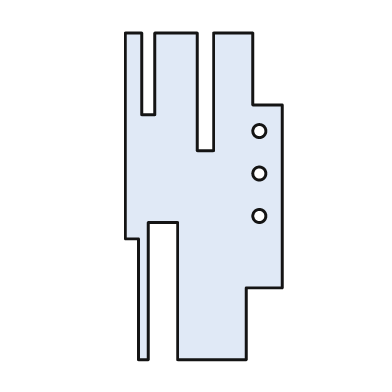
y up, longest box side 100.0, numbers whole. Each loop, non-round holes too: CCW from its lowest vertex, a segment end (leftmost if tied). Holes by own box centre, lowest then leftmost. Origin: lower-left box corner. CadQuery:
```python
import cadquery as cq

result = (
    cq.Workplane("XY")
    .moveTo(4.0, 0.0)
    .lineTo(7.0, 0.0)
    .lineTo(7.0, 42.0)
    .lineTo(16.0, 42.0)
    .lineTo(16.0, 0.0)
    .lineTo(37.0, 0.0)
    .lineTo(37.0, 22.0)
    .lineTo(48.0, 22.0)
    .lineTo(48.0, 78.0)
    .lineTo(39.0, 78.0)
    .lineTo(39.0, 100.0)
    .lineTo(27.0, 100.0)
    .lineTo(27.0, 64.0)
    .lineTo(22.0, 64.0)
    .lineTo(22.0, 100.0)
    .lineTo(9.0, 100.0)
    .lineTo(9.0, 75.0)
    .lineTo(5.0, 75.0)
    .lineTo(5.0, 100.0)
    .lineTo(0.0, 100.0)
    .lineTo(0.0, 37.0)
    .lineTo(4.0, 37.0)
    .close()
    .moveTo(41.0, 44.0)
    .circle(2.0)
    .moveTo(41.0, 57.0)
    .circle(2.0)
    .moveTo(41.0, 70.0)
    .circle(2.0)
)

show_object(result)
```